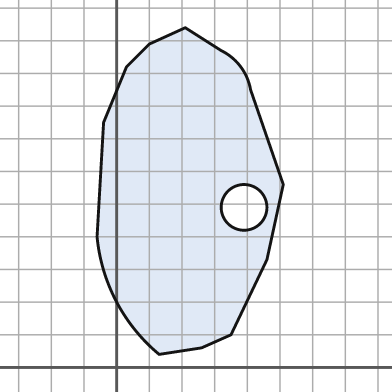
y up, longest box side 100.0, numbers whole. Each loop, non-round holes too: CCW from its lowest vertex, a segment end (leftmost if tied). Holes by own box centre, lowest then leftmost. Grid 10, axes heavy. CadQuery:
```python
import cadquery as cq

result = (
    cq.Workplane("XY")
    .moveTo(13.0, 4.0)
    .lineTo(26.0, 6.0)
    .lineTo(35.0, 10.0)
    .lineTo(46.0, 33.0)
    .lineTo(51.0, 56.0)
    .lineTo(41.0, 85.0)
    .threePointArc((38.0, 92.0), (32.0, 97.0))
    .lineTo(21.0, 104.0)
    .lineTo(10.0, 99.0)
    .lineTo(3.0, 92.0)
    .lineTo(-4.0, 75.0)
    .lineTo(-6.0, 40.0)
    .threePointArc((0.0, 20.0), (13.0, 4.0))
    .close()
    .moveTo(39.0, 49.0)
    .circle(7.0)
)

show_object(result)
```